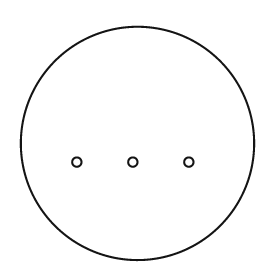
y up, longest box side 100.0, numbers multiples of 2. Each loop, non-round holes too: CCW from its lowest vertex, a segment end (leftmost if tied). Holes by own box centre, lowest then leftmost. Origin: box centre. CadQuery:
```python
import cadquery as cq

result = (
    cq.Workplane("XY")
    .moveTo(0.0, 0.0)
    .circle(50.0)
    .moveTo(-26.0, -8.0)
    .circle(2.0)
    .moveTo(-2.0, -8.0)
    .circle(2.0)
    .moveTo(22.0, -8.0)
    .circle(2.0)
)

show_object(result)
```